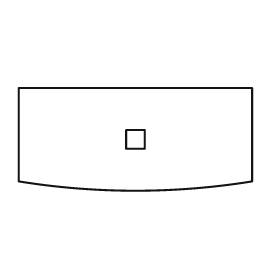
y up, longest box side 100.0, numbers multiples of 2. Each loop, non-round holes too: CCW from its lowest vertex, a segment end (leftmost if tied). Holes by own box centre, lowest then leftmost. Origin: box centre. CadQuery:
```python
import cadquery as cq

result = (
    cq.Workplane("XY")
    .moveTo(-50.0, -18.0)
    .threePointArc((0.0, -22.0), (50.0, -18.0))
    .lineTo(50.0, 22.0)
    .lineTo(-50.0, 22.0)
    .close()
    .moveTo(-4.0, -4.0)
    .lineTo(4.0, -4.0)
    .lineTo(4.0, 4.0)
    .lineTo(-4.0, 4.0)
    .close()
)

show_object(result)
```